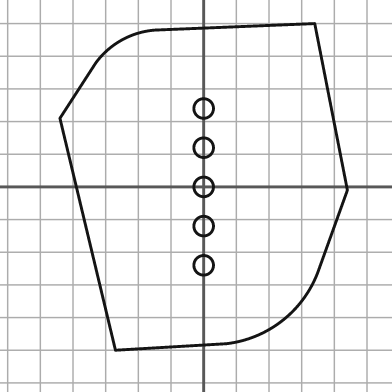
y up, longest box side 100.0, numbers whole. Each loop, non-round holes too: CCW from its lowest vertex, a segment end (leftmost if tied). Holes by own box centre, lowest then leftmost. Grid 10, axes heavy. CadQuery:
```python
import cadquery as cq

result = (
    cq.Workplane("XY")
    .moveTo(-27.0, -50.0)
    .lineTo(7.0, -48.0)
    .threePointArc((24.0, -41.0), (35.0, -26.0))
    .lineTo(44.0, -1.0)
    .lineTo(34.0, 50.0)
    .lineTo(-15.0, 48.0)
    .threePointArc((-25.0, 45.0), (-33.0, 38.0))
    .lineTo(-44.0, 21.0)
    .close()
    .moveTo(0.0, -24.0)
    .circle(3.0)
    .moveTo(0.0, -12.0)
    .circle(3.0)
    .moveTo(0.0, 0.0)
    .circle(3.0)
    .moveTo(0.0, 12.0)
    .circle(3.0)
    .moveTo(0.0, 24.0)
    .circle(3.0)
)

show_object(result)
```